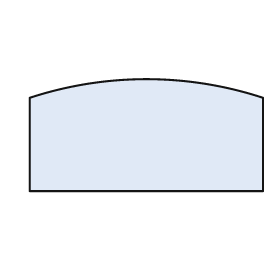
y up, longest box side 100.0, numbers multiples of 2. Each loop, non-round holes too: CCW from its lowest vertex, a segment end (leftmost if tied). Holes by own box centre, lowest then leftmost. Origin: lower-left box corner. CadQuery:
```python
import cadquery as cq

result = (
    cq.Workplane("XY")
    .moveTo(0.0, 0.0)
    .lineTo(100.0, 0.0)
    .lineTo(100.0, 40.0)
    .threePointArc((50.0, 48.0), (0.0, 40.0))
    .close()
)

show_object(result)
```